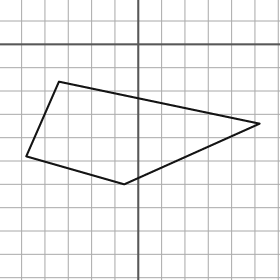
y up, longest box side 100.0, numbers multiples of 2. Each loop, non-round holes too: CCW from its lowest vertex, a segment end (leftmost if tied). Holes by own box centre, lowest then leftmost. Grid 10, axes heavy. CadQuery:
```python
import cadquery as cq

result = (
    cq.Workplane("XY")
    .moveTo(-6.0, -60.0)
    .lineTo(52.0, -34.0)
    .lineTo(-34.0, -16.0)
    .lineTo(-48.0, -48.0)
    .close()
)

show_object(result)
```